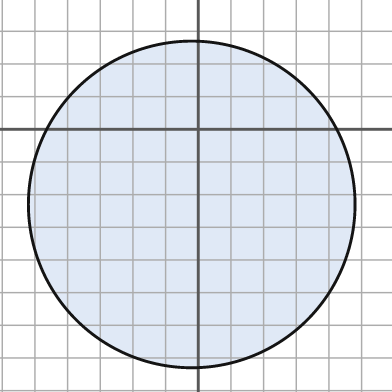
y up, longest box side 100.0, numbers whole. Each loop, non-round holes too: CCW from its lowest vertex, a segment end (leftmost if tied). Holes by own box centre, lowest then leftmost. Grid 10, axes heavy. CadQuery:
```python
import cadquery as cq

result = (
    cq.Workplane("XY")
    .moveTo(-2.0, -23.0)
    .circle(50.0)
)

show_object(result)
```